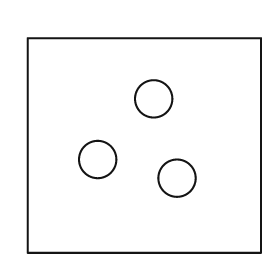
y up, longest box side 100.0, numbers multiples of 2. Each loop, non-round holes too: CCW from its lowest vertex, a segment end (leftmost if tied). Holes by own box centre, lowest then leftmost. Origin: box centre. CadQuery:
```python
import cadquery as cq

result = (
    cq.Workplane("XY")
    .moveTo(-50.0, -46.0)
    .lineTo(50.0, -46.0)
    .lineTo(50.0, 46.0)
    .lineTo(-50.0, 46.0)
    .close()
    .moveTo(14.0, -14.0)
    .circle(8.0)
    .moveTo(-20.0, -6.0)
    .circle(8.0)
    .moveTo(4.0, 20.0)
    .circle(8.0)
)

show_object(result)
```